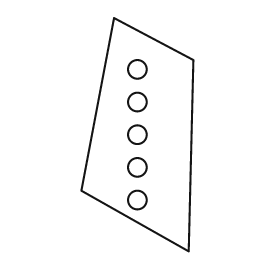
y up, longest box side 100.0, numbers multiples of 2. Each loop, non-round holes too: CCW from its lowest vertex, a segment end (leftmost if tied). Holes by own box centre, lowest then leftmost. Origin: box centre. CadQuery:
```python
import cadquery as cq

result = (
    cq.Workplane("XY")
    .moveTo(22.0, -50.0)
    .lineTo(24.0, 32.0)
    .lineTo(-10.0, 50.0)
    .lineTo(-24.0, -24.0)
    .close()
    .moveTo(0.0, -28.0)
    .circle(4.0)
    .moveTo(0.0, -14.0)
    .circle(4.0)
    .moveTo(0.0, 0.0)
    .circle(4.0)
    .moveTo(0.0, 14.0)
    .circle(4.0)
    .moveTo(0.0, 28.0)
    .circle(4.0)
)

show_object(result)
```